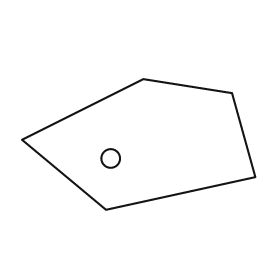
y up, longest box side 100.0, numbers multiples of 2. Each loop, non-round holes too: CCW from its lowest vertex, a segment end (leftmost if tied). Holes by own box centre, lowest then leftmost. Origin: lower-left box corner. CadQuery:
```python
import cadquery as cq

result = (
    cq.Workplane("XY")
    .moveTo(36.0, 0.0)
    .lineTo(100.0, 14.0)
    .lineTo(90.0, 50.0)
    .lineTo(52.0, 56.0)
    .lineTo(0.0, 30.0)
    .close()
    .moveTo(38.0, 22.0)
    .circle(4.0)
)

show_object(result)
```